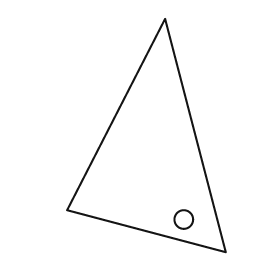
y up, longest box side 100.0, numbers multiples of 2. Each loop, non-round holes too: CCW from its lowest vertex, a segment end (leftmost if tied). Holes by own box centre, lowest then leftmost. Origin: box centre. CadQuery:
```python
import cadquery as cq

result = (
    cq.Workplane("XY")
    .moveTo(34.0, -50.0)
    .lineTo(8.0, 50.0)
    .lineTo(-34.0, -32.0)
    .close()
    .moveTo(16.0, -36.0)
    .circle(4.0)
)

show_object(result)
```